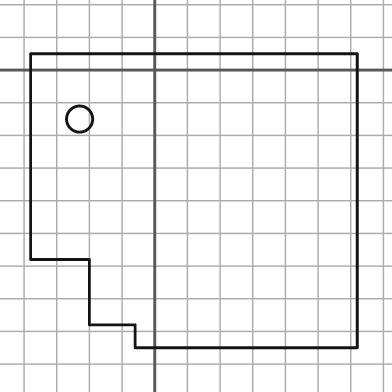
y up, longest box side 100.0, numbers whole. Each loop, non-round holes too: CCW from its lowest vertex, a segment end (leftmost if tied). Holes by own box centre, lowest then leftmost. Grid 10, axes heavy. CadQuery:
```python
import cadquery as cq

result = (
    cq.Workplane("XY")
    .moveTo(-6.0, -85.0)
    .lineTo(62.0, -85.0)
    .lineTo(62.0, 5.0)
    .lineTo(-38.0, 5.0)
    .lineTo(-38.0, -58.0)
    .lineTo(-20.0, -58.0)
    .lineTo(-20.0, -78.0)
    .lineTo(-6.0, -78.0)
    .close()
    .moveTo(-23.0, -15.0)
    .circle(4.0)
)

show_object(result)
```